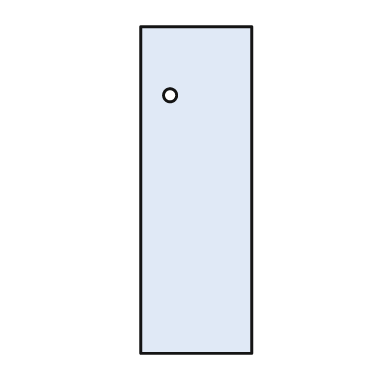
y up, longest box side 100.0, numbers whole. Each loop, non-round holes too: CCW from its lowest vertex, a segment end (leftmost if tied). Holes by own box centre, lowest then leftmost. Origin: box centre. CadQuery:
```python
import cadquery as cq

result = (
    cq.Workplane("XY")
    .moveTo(-17.0, -50.0)
    .lineTo(17.0, -50.0)
    .lineTo(17.0, 50.0)
    .lineTo(-17.0, 50.0)
    .close()
    .moveTo(-8.0, 29.0)
    .circle(2.0)
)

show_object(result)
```